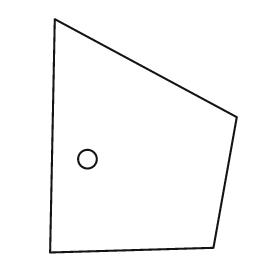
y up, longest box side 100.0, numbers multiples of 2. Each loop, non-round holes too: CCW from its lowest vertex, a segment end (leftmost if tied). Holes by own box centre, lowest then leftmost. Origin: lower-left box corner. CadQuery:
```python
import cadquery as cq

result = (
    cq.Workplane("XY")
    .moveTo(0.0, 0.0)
    .lineTo(70.0, 2.0)
    .lineTo(80.0, 58.0)
    .lineTo(2.0, 100.0)
    .close()
    .moveTo(16.0, 40.0)
    .circle(4.0)
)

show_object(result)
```